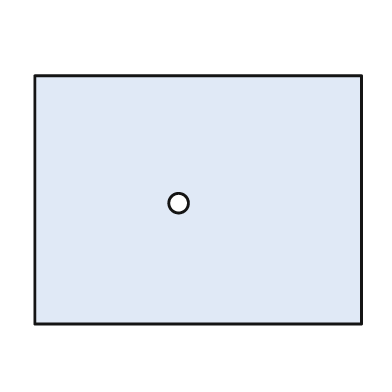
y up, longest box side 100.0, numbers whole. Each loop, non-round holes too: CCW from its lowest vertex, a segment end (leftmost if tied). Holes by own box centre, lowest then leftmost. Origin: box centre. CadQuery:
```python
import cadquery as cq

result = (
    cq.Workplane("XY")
    .moveTo(-50.0, -38.0)
    .lineTo(50.0, -38.0)
    .lineTo(50.0, 38.0)
    .lineTo(-50.0, 38.0)
    .close()
    .moveTo(-6.0, -1.0)
    .circle(3.0)
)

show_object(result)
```